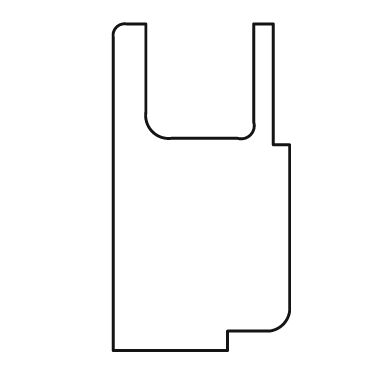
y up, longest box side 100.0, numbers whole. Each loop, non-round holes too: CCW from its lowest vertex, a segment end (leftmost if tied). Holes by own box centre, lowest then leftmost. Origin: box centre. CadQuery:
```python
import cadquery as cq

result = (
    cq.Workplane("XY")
    .moveTo(-27.0, -50.0)
    .lineTo(8.0, -50.0)
    .lineTo(8.0, -44.0)
    .lineTo(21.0, -44.0)
    .threePointArc((25.0, -42.0), (27.0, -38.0))
    .lineTo(27.0, 13.0)
    .lineTo(22.0, 13.0)
    .lineTo(22.0, 50.0)
    .lineTo(16.0, 50.0)
    .lineTo(16.0, 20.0)
    .threePointArc((15.0, 16.0), (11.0, 15.0))
    .lineTo(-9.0, 15.0)
    .threePointArc((-15.0, 17.0), (-17.0, 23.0))
    .lineTo(-17.0, 50.0)
    .lineTo(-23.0, 50.0)
    .threePointArc((-26.0, 49.0), (-27.0, 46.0))
    .close()
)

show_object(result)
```